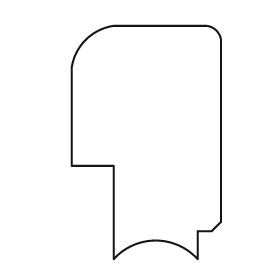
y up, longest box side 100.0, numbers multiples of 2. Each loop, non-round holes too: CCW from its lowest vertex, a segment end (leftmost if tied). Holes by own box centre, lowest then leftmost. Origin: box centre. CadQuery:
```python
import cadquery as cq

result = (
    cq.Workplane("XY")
    .moveTo(-14.0, -50.0)
    .threePointArc((4.0, -42.0), (22.0, -50.0))
    .lineTo(22.0, -38.0)
    .lineTo(28.0, -38.0)
    .lineTo(32.0, -34.0)
    .lineTo(32.0, 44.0)
    .threePointArc((30.0, 48.0), (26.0, 50.0))
    .lineTo(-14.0, 50.0)
    .threePointArc((-26.0, 44.0), (-32.0, 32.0))
    .lineTo(-32.0, -10.0)
    .lineTo(-14.0, -10.0)
    .close()
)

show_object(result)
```